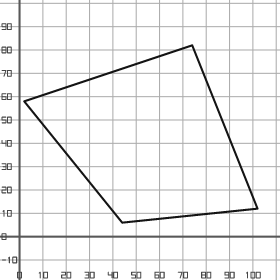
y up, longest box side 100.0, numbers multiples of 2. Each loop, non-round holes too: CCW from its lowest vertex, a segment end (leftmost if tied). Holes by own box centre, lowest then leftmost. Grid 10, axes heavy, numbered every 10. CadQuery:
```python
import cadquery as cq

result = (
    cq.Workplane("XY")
    .moveTo(44.0, 6.0)
    .lineTo(102.0, 12.0)
    .lineTo(74.0, 82.0)
    .lineTo(2.0, 58.0)
    .close()
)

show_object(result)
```